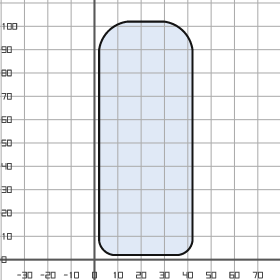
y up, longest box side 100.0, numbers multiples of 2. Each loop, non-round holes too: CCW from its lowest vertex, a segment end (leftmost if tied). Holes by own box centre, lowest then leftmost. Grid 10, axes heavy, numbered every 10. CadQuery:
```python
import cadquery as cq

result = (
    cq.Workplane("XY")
    .moveTo(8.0, 2.0)
    .lineTo(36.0, 2.0)
    .threePointArc((40.0, 4.0), (42.0, 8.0))
    .lineTo(42.0, 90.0)
    .threePointArc((38.0, 98.0), (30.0, 102.0))
    .lineTo(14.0, 102.0)
    .threePointArc((6.0, 98.0), (2.0, 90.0))
    .lineTo(2.0, 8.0)
    .threePointArc((4.0, 4.0), (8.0, 2.0))
    .close()
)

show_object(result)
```